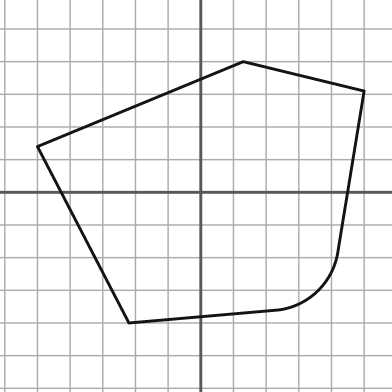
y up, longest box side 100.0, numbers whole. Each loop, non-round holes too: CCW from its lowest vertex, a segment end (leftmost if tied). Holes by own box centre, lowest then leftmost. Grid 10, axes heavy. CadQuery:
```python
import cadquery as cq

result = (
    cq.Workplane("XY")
    .moveTo(-22.0, -40.0)
    .lineTo(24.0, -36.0)
    .threePointArc((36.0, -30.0), (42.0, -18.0))
    .lineTo(50.0, 31.0)
    .lineTo(13.0, 40.0)
    .lineTo(-50.0, 14.0)
    .close()
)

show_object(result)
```